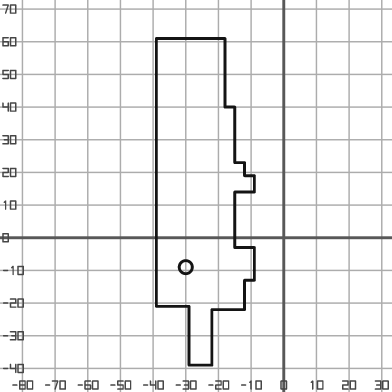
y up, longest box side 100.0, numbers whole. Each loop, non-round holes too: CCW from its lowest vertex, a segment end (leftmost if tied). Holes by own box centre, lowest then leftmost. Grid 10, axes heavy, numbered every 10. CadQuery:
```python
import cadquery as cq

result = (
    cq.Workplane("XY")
    .moveTo(-29.0, -39.0)
    .lineTo(-22.0, -39.0)
    .lineTo(-22.0, -22.0)
    .lineTo(-12.0, -22.0)
    .lineTo(-12.0, -13.0)
    .lineTo(-9.0, -13.0)
    .lineTo(-9.0, -3.0)
    .lineTo(-15.0, -3.0)
    .lineTo(-15.0, 14.0)
    .lineTo(-9.0, 14.0)
    .lineTo(-9.0, 19.0)
    .lineTo(-12.0, 19.0)
    .lineTo(-12.0, 23.0)
    .lineTo(-15.0, 23.0)
    .lineTo(-15.0, 40.0)
    .lineTo(-18.0, 40.0)
    .lineTo(-18.0, 61.0)
    .lineTo(-39.0, 61.0)
    .lineTo(-39.0, -21.0)
    .lineTo(-29.0, -21.0)
    .close()
    .moveTo(-30.0, -9.0)
    .circle(2.0)
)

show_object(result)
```